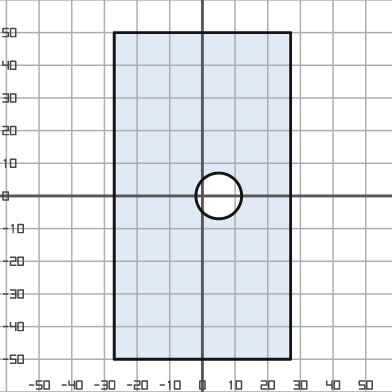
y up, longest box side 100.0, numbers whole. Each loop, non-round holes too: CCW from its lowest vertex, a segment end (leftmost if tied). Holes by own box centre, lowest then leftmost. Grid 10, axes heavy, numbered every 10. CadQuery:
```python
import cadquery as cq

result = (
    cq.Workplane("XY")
    .moveTo(-27.0, -50.0)
    .lineTo(27.0, -50.0)
    .lineTo(27.0, 50.0)
    .lineTo(-27.0, 50.0)
    .close()
    .moveTo(5.0, 0.0)
    .circle(7.0)
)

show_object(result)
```